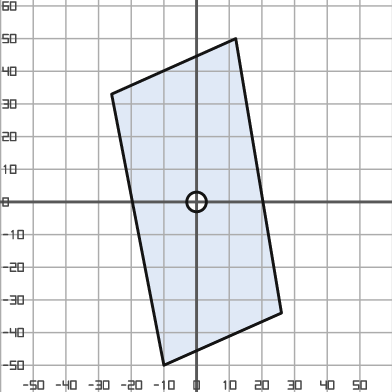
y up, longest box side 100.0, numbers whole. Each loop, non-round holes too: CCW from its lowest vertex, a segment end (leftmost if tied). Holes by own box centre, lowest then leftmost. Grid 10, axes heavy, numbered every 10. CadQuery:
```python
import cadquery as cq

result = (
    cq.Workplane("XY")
    .moveTo(-10.0, -50.0)
    .lineTo(26.0, -34.0)
    .lineTo(12.0, 50.0)
    .lineTo(-26.0, 33.0)
    .close()
    .moveTo(0.0, 0.0)
    .circle(3.0)
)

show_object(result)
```